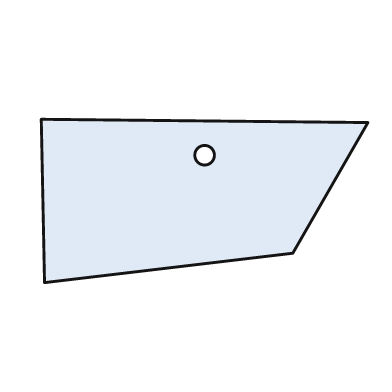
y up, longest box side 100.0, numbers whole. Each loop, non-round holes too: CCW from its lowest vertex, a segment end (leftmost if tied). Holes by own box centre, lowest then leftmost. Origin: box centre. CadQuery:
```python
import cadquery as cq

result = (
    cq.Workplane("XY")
    .moveTo(-49.0, -25.0)
    .lineTo(27.0, -16.0)
    .lineTo(50.0, 24.0)
    .lineTo(-50.0, 25.0)
    .close()
    .moveTo(0.0, 14.0)
    .circle(3.0)
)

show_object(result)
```